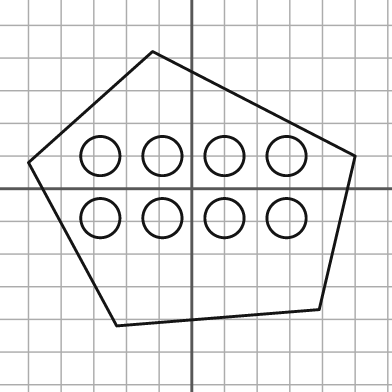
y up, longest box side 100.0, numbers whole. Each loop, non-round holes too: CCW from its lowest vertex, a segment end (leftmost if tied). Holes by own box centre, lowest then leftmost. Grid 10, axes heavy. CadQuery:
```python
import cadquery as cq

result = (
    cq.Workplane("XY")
    .moveTo(-23.0, -42.0)
    .lineTo(39.0, -37.0)
    .lineTo(50.0, 10.0)
    .lineTo(-12.0, 42.0)
    .lineTo(-50.0, 8.0)
    .close()
    .moveTo(-28.0, -9.0)
    .circle(6.0)
    .moveTo(-9.0, -9.0)
    .circle(6.0)
    .moveTo(10.0, -9.0)
    .circle(6.0)
    .moveTo(29.0, -9.0)
    .circle(6.0)
    .moveTo(-28.0, 10.0)
    .circle(6.0)
    .moveTo(-9.0, 10.0)
    .circle(6.0)
    .moveTo(10.0, 10.0)
    .circle(6.0)
    .moveTo(29.0, 10.0)
    .circle(6.0)
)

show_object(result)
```